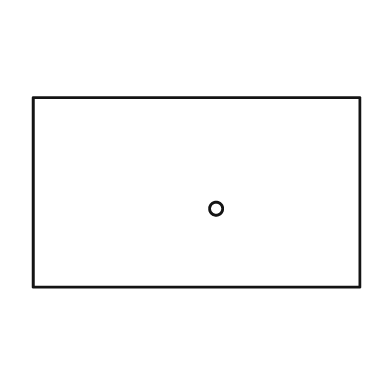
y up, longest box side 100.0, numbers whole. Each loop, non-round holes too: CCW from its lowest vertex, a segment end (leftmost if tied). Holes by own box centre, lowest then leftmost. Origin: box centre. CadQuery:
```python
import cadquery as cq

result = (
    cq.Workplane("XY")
    .moveTo(-50.0, -29.0)
    .lineTo(50.0, -29.0)
    .lineTo(50.0, 29.0)
    .lineTo(-50.0, 29.0)
    .close()
    .moveTo(6.0, -5.0)
    .circle(2.0)
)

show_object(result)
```